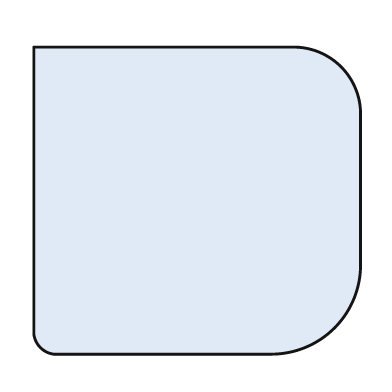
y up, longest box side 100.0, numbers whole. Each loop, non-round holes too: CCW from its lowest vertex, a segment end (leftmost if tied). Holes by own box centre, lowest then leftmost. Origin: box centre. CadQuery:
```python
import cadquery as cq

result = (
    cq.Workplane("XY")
    .moveTo(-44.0, -47.0)
    .lineTo(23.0, -47.0)
    .threePointArc((42.0, -39.0), (50.0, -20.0))
    .lineTo(50.0, 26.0)
    .threePointArc((44.0, 41.0), (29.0, 47.0))
    .lineTo(-50.0, 47.0)
    .lineTo(-50.0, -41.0)
    .threePointArc((-48.0, -45.0), (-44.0, -47.0))
    .close()
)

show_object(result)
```